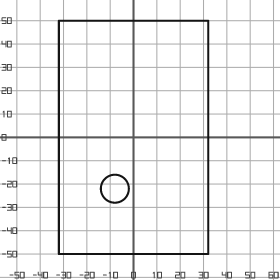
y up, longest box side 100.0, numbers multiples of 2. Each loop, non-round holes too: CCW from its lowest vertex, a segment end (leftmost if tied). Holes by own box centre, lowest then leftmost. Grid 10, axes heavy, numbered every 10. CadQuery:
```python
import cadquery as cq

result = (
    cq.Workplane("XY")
    .moveTo(-32.0, -50.0)
    .lineTo(32.0, -50.0)
    .lineTo(32.0, 50.0)
    .lineTo(-32.0, 50.0)
    .close()
    .moveTo(-8.0, -22.0)
    .circle(6.0)
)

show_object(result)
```